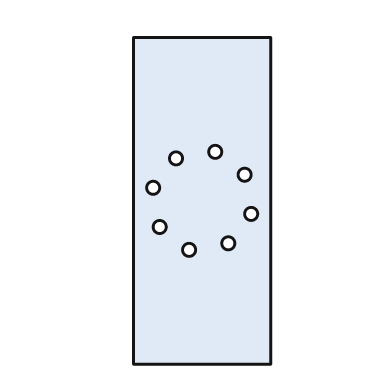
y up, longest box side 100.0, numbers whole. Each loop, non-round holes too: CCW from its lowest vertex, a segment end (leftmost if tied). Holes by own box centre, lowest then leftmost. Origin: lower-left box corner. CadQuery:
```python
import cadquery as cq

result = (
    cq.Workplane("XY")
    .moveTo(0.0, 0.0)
    .lineTo(42.0, 0.0)
    .lineTo(42.0, 100.0)
    .lineTo(0.0, 100.0)
    .close()
    .moveTo(17.0, 35.0)
    .circle(2.0)
    .moveTo(29.0, 37.0)
    .circle(2.0)
    .moveTo(8.0, 42.0)
    .circle(2.0)
    .moveTo(36.0, 46.0)
    .circle(2.0)
    .moveTo(6.0, 54.0)
    .circle(2.0)
    .moveTo(34.0, 58.0)
    .circle(2.0)
    .moveTo(13.0, 63.0)
    .circle(2.0)
    .moveTo(25.0, 65.0)
    .circle(2.0)
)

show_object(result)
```